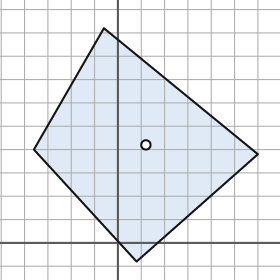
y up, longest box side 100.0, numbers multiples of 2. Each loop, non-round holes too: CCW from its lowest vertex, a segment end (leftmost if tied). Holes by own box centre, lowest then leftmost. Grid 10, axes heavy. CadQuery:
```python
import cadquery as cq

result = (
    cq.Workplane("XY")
    .moveTo(8.0, -8.0)
    .lineTo(60.0, 38.0)
    .lineTo(-6.0, 92.0)
    .lineTo(-36.0, 40.0)
    .close()
    .moveTo(12.0, 42.0)
    .circle(2.0)
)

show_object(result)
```